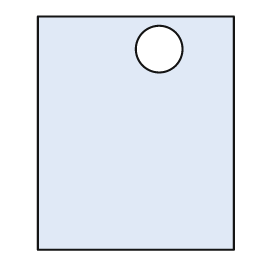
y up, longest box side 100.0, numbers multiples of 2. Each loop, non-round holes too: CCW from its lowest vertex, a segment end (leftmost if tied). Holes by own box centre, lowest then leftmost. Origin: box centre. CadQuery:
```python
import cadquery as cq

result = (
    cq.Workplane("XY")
    .moveTo(-42.0, -50.0)
    .lineTo(42.0, -50.0)
    .lineTo(42.0, 50.0)
    .lineTo(-42.0, 50.0)
    .close()
    .moveTo(10.0, 36.0)
    .circle(10.0)
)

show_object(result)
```